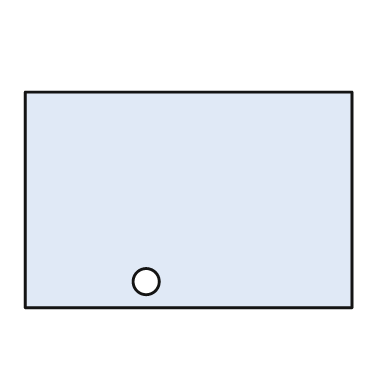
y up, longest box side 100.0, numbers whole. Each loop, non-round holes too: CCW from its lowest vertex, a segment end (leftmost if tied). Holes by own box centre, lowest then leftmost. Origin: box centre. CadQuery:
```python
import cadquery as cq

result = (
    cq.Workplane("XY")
    .moveTo(-50.0, -33.0)
    .lineTo(50.0, -33.0)
    .lineTo(50.0, 33.0)
    .lineTo(-50.0, 33.0)
    .close()
    .moveTo(-13.0, -25.0)
    .circle(4.0)
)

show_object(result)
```